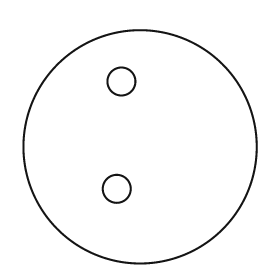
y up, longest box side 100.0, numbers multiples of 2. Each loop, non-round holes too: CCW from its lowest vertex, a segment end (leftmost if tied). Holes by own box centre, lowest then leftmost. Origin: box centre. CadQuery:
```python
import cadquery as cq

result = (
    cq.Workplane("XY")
    .moveTo(0.0, 0.0)
    .circle(50.0)
    .moveTo(-10.0, -18.0)
    .circle(6.0)
    .moveTo(-8.0, 28.0)
    .circle(6.0)
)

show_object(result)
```